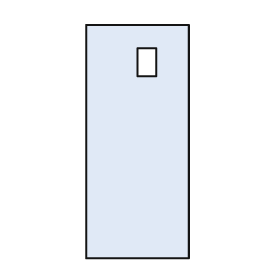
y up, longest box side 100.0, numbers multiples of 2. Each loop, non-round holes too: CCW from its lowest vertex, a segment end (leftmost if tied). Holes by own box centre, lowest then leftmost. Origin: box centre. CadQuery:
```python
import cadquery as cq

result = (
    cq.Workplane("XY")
    .moveTo(-22.0, -50.0)
    .lineTo(22.0, -50.0)
    .lineTo(22.0, 50.0)
    .lineTo(-22.0, 50.0)
    .close()
    .moveTo(0.0, 28.0)
    .lineTo(8.0, 28.0)
    .lineTo(8.0, 40.0)
    .lineTo(0.0, 40.0)
    .close()
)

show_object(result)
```